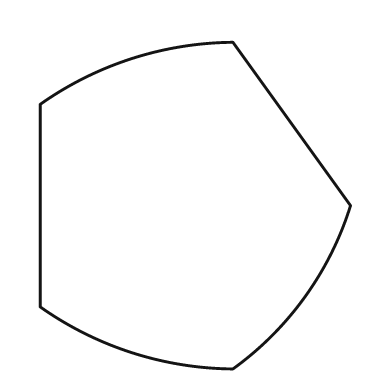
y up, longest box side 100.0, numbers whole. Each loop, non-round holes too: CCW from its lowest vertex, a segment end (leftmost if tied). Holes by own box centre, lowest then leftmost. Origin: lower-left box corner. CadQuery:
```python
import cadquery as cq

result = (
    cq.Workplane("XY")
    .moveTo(59.0, 0.0)
    .threePointArc((81.0, 22.0), (95.0, 50.0))
    .lineTo(59.0, 100.0)
    .threePointArc((28.0, 95.0), (0.0, 81.0))
    .lineTo(0.0, 19.0)
    .threePointArc((28.0, 5.0), (59.0, 0.0))
    .close()
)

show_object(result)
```